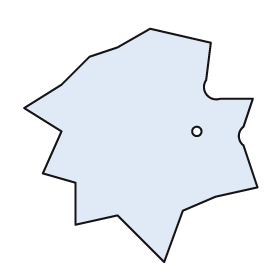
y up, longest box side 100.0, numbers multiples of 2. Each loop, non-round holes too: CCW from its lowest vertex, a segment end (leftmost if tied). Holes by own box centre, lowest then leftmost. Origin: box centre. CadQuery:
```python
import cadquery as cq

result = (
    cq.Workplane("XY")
    .moveTo(10.0, -50.0)
    .lineTo(18.0, -28.0)
    .lineTo(32.0, -22.0)
    .lineTo(50.0, -18.0)
    .lineTo(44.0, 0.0)
    .threePointArc((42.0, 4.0), (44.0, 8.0))
    .lineTo(48.0, 20.0)
    .lineTo(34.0, 20.0)
    .threePointArc((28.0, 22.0), (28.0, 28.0))
    .lineTo(30.0, 44.0)
    .lineTo(4.0, 50.0)
    .lineTo(-10.0, 42.0)
    .lineTo(-22.0, 38.0)
    .lineTo(-34.0, 26.0)
    .lineTo(-50.0, 16.0)
    .lineTo(-34.0, 6.0)
    .lineTo(-42.0, -12.0)
    .lineTo(-28.0, -16.0)
    .lineTo(-28.0, -34.0)
    .lineTo(-10.0, -30.0)
    .close()
    .moveTo(24.0, 6.0)
    .circle(2.0)
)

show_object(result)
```